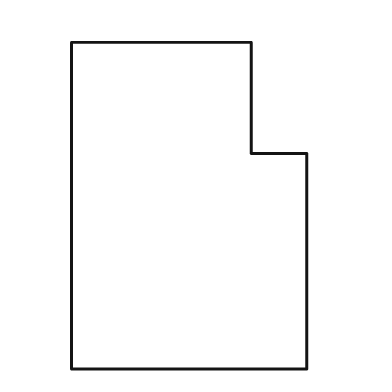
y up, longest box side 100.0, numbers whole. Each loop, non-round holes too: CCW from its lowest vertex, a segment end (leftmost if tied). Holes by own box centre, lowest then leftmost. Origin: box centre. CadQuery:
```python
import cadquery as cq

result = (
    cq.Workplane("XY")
    .moveTo(-36.0, -50.0)
    .lineTo(36.0, -50.0)
    .lineTo(36.0, 16.0)
    .lineTo(19.0, 16.0)
    .lineTo(19.0, 50.0)
    .lineTo(-36.0, 50.0)
    .close()
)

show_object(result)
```